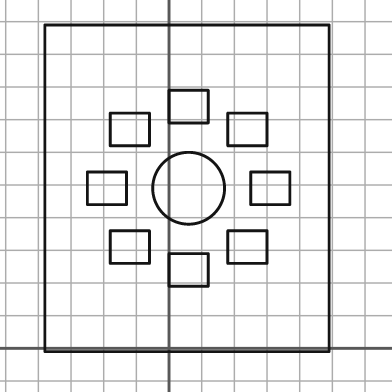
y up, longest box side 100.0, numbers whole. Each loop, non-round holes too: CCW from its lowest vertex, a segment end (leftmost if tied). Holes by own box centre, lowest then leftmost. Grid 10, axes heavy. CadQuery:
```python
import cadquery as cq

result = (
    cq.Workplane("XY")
    .moveTo(-38.0, -1.0)
    .lineTo(49.0, -1.0)
    .lineTo(49.0, 99.0)
    .lineTo(-38.0, 99.0)
    .close()
    .moveTo(0.0, 19.0)
    .lineTo(12.0, 19.0)
    .lineTo(12.0, 29.0)
    .lineTo(0.0, 29.0)
    .close()
    .moveTo(-18.0, 26.0)
    .lineTo(-6.0, 26.0)
    .lineTo(-6.0, 36.0)
    .lineTo(-18.0, 36.0)
    .close()
    .moveTo(18.0, 26.0)
    .lineTo(30.0, 26.0)
    .lineTo(30.0, 36.0)
    .lineTo(18.0, 36.0)
    .close()
    .moveTo(-25.0, 44.0)
    .lineTo(-13.0, 44.0)
    .lineTo(-13.0, 54.0)
    .lineTo(-25.0, 54.0)
    .close()
    .moveTo(6.0, 49.0)
    .circle(11.0)
    .moveTo(25.0, 44.0)
    .lineTo(37.0, 44.0)
    .lineTo(37.0, 54.0)
    .lineTo(25.0, 54.0)
    .close()
    .moveTo(-18.0, 62.0)
    .lineTo(-6.0, 62.0)
    .lineTo(-6.0, 72.0)
    .lineTo(-18.0, 72.0)
    .close()
    .moveTo(18.0, 62.0)
    .lineTo(30.0, 62.0)
    .lineTo(30.0, 72.0)
    .lineTo(18.0, 72.0)
    .close()
    .moveTo(0.0, 69.0)
    .lineTo(12.0, 69.0)
    .lineTo(12.0, 79.0)
    .lineTo(0.0, 79.0)
    .close()
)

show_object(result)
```